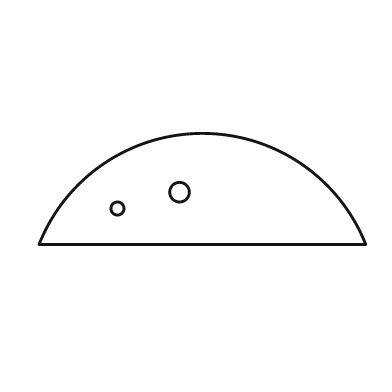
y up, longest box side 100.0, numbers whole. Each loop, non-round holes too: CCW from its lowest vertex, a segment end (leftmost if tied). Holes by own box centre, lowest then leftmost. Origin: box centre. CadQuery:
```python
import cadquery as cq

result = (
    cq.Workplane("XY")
    .moveTo(-50.0, -17.0)
    .lineTo(50.0, -17.0)
    .threePointArc((0.0, 17.0), (-50.0, -17.0))
    .close()
    .moveTo(-26.0, -6.0)
    .circle(2.0)
    .moveTo(-7.0, -1.0)
    .circle(3.0)
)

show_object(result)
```